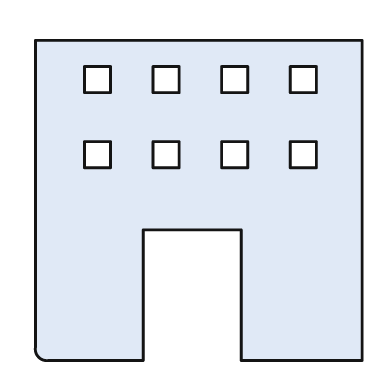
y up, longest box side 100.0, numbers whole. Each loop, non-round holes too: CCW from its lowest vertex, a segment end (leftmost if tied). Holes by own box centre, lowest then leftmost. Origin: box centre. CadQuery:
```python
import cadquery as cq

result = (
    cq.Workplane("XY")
    .moveTo(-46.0, -49.0)
    .lineTo(-17.0, -49.0)
    .lineTo(-17.0, -9.0)
    .lineTo(13.0, -9.0)
    .lineTo(13.0, -49.0)
    .lineTo(50.0, -49.0)
    .lineTo(50.0, 49.0)
    .lineTo(-50.0, 49.0)
    .lineTo(-50.0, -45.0)
    .threePointArc((-49.0, -48.0), (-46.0, -49.0))
    .close()
    .moveTo(-35.0, 10.0)
    .lineTo(-27.0, 10.0)
    .lineTo(-27.0, 18.0)
    .lineTo(-35.0, 18.0)
    .close()
    .moveTo(-14.0, 10.0)
    .lineTo(-6.0, 10.0)
    .lineTo(-6.0, 18.0)
    .lineTo(-14.0, 18.0)
    .close()
    .moveTo(7.0, 10.0)
    .lineTo(15.0, 10.0)
    .lineTo(15.0, 18.0)
    .lineTo(7.0, 18.0)
    .close()
    .moveTo(28.0, 10.0)
    .lineTo(36.0, 10.0)
    .lineTo(36.0, 18.0)
    .lineTo(28.0, 18.0)
    .close()
    .moveTo(-35.0, 33.0)
    .lineTo(-27.0, 33.0)
    .lineTo(-27.0, 41.0)
    .lineTo(-35.0, 41.0)
    .close()
    .moveTo(-14.0, 33.0)
    .lineTo(-6.0, 33.0)
    .lineTo(-6.0, 41.0)
    .lineTo(-14.0, 41.0)
    .close()
    .moveTo(7.0, 33.0)
    .lineTo(15.0, 33.0)
    .lineTo(15.0, 41.0)
    .lineTo(7.0, 41.0)
    .close()
    .moveTo(28.0, 33.0)
    .lineTo(36.0, 33.0)
    .lineTo(36.0, 41.0)
    .lineTo(28.0, 41.0)
    .close()
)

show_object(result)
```